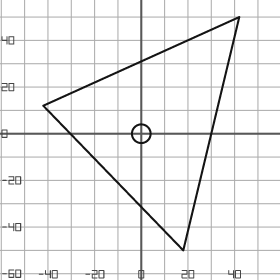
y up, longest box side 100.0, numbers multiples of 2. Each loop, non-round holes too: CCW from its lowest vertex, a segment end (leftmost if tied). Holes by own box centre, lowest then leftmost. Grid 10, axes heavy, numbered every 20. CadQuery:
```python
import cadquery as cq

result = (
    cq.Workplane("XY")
    .moveTo(18.0, -50.0)
    .lineTo(42.0, 50.0)
    .lineTo(-42.0, 12.0)
    .close()
    .moveTo(0.0, 0.0)
    .circle(4.0)
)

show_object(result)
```